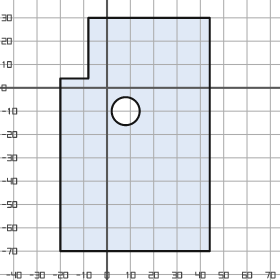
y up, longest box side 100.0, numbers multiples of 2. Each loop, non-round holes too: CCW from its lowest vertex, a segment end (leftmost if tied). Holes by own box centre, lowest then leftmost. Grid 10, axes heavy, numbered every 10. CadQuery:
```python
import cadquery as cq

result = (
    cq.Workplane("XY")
    .moveTo(-20.0, -70.0)
    .lineTo(44.0, -70.0)
    .lineTo(44.0, 30.0)
    .lineTo(-8.0, 30.0)
    .lineTo(-8.0, 4.0)
    .lineTo(-20.0, 4.0)
    .close()
    .moveTo(8.0, -10.0)
    .circle(6.0)
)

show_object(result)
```